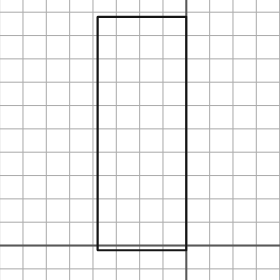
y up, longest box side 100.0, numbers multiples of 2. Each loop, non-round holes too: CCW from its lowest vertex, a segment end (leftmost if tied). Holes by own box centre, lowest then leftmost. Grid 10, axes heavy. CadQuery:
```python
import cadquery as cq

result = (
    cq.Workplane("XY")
    .moveTo(-38.0, -2.0)
    .lineTo(0.0, -2.0)
    .lineTo(0.0, 98.0)
    .lineTo(-38.0, 98.0)
    .close()
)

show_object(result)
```